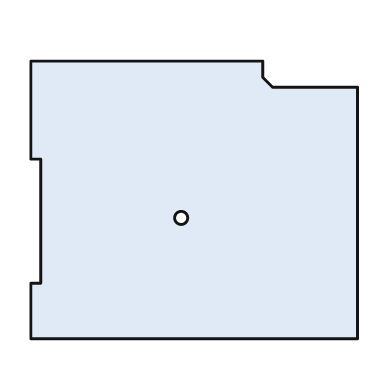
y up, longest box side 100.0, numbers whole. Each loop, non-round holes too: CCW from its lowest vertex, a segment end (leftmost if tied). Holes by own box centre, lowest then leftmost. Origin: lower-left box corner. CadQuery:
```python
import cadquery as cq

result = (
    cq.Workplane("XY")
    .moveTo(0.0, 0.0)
    .lineTo(100.0, 0.0)
    .lineTo(100.0, 77.0)
    .lineTo(74.0, 77.0)
    .lineTo(71.0, 80.0)
    .lineTo(71.0, 85.0)
    .lineTo(0.0, 85.0)
    .lineTo(0.0, 55.0)
    .lineTo(3.0, 55.0)
    .lineTo(3.0, 17.0)
    .lineTo(0.0, 17.0)
    .close()
    .moveTo(46.0, 37.0)
    .circle(2.0)
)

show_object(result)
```